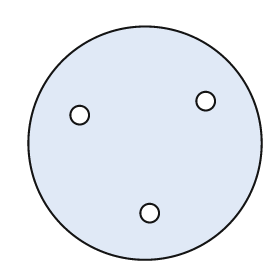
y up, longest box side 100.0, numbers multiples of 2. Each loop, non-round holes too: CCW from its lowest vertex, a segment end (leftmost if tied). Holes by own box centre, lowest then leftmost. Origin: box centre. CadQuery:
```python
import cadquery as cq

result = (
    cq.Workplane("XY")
    .moveTo(0.0, 0.0)
    .circle(50.0)
    .moveTo(2.0, -30.0)
    .circle(4.0)
    .moveTo(-28.0, 12.0)
    .circle(4.0)
    .moveTo(26.0, 18.0)
    .circle(4.0)
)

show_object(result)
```